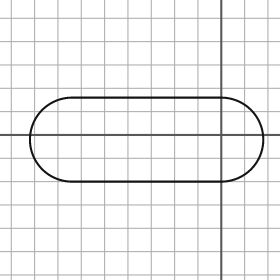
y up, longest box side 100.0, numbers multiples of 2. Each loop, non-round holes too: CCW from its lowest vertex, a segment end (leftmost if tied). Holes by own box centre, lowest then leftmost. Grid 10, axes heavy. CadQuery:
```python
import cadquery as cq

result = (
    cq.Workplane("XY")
    .moveTo(-64.0, -20.0)
    .lineTo(0.0, -20.0)
    .threePointArc((18.0, -2.0), (0.0, 16.0))
    .lineTo(-64.0, 16.0)
    .threePointArc((-82.0, -2.0), (-64.0, -20.0))
    .close()
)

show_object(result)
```